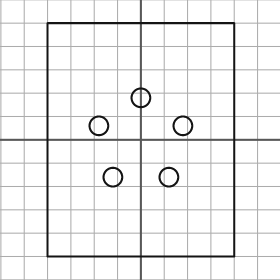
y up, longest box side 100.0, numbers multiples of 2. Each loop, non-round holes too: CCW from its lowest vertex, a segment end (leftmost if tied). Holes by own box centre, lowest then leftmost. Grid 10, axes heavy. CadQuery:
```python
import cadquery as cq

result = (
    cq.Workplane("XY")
    .moveTo(-40.0, -50.0)
    .lineTo(40.0, -50.0)
    .lineTo(40.0, 50.0)
    .lineTo(-40.0, 50.0)
    .close()
    .moveTo(-12.0, -16.0)
    .circle(4.0)
    .moveTo(12.0, -16.0)
    .circle(4.0)
    .moveTo(-18.0, 6.0)
    .circle(4.0)
    .moveTo(18.0, 6.0)
    .circle(4.0)
    .moveTo(0.0, 18.0)
    .circle(4.0)
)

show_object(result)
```